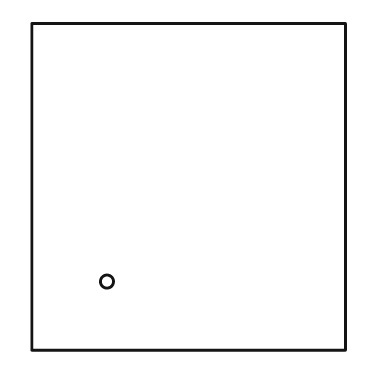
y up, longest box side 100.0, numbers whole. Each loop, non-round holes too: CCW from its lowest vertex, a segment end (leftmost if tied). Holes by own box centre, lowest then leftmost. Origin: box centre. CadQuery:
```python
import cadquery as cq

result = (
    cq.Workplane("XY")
    .moveTo(-48.0, -50.0)
    .lineTo(48.0, -50.0)
    .lineTo(48.0, 50.0)
    .lineTo(-48.0, 50.0)
    .close()
    .moveTo(-25.0, -29.0)
    .circle(2.0)
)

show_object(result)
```